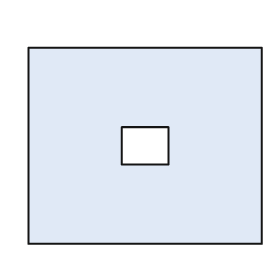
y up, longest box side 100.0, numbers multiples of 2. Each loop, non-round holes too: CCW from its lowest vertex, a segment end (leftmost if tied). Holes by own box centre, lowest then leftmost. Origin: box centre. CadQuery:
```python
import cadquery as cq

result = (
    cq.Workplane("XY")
    .moveTo(-50.0, -42.0)
    .lineTo(50.0, -42.0)
    .lineTo(50.0, 42.0)
    .lineTo(-50.0, 42.0)
    .close()
    .moveTo(-10.0, -8.0)
    .lineTo(10.0, -8.0)
    .lineTo(10.0, 8.0)
    .lineTo(-10.0, 8.0)
    .close()
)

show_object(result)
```